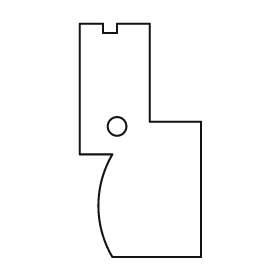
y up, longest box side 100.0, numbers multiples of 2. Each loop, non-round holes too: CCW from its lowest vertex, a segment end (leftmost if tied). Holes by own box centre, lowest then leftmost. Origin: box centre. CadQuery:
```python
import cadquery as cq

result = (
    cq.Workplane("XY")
    .moveTo(-12.0, -50.0)
    .lineTo(26.0, -50.0)
    .lineTo(26.0, 8.0)
    .lineTo(4.0, 8.0)
    .lineTo(4.0, 50.0)
    .lineTo(-10.0, 50.0)
    .lineTo(-10.0, 46.0)
    .lineTo(-16.0, 46.0)
    .lineTo(-16.0, 50.0)
    .lineTo(-26.0, 50.0)
    .lineTo(-26.0, -6.0)
    .lineTo(-12.0, -6.0)
    .threePointArc((-18.0, -28.0), (-12.0, -50.0))
    .close()
    .moveTo(-10.0, 6.0)
    .circle(4.0)
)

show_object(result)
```